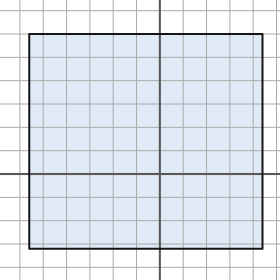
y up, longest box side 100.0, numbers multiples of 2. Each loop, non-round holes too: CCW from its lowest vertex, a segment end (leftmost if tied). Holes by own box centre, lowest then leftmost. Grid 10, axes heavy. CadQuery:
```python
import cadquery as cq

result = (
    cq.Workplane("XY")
    .moveTo(-56.0, -32.0)
    .lineTo(44.0, -32.0)
    .lineTo(44.0, 60.0)
    .lineTo(-56.0, 60.0)
    .close()
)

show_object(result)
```